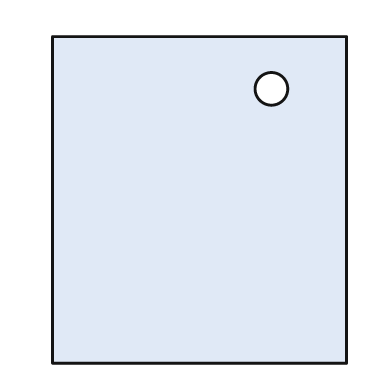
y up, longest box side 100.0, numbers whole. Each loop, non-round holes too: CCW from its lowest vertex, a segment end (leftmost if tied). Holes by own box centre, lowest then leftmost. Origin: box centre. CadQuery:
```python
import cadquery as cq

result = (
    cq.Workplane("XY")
    .moveTo(-45.0, -50.0)
    .lineTo(45.0, -50.0)
    .lineTo(45.0, 50.0)
    .lineTo(-45.0, 50.0)
    .close()
    .moveTo(22.0, 34.0)
    .circle(5.0)
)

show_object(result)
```